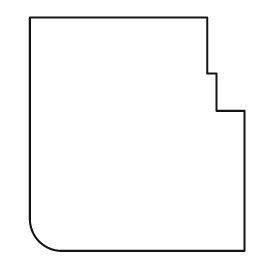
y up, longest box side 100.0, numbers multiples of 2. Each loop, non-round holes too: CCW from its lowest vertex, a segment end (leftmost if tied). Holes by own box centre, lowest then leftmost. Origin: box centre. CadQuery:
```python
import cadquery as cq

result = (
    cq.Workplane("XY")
    .moveTo(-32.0, -50.0)
    .lineTo(46.0, -50.0)
    .lineTo(46.0, 10.0)
    .lineTo(34.0, 10.0)
    .lineTo(34.0, 26.0)
    .lineTo(30.0, 26.0)
    .lineTo(30.0, 50.0)
    .lineTo(-46.0, 50.0)
    .lineTo(-46.0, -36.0)
    .threePointArc((-42.0, -46.0), (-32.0, -50.0))
    .close()
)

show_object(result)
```